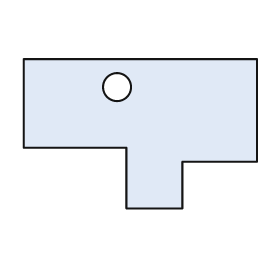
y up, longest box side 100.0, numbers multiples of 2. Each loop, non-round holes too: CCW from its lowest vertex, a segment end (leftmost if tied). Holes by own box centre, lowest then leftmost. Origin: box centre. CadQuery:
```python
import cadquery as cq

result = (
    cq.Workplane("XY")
    .moveTo(-6.0, -32.0)
    .lineTo(18.0, -32.0)
    .lineTo(18.0, -12.0)
    .lineTo(50.0, -12.0)
    .lineTo(50.0, 32.0)
    .lineTo(-50.0, 32.0)
    .lineTo(-50.0, -6.0)
    .lineTo(-6.0, -6.0)
    .close()
    .moveTo(-10.0, 20.0)
    .circle(6.0)
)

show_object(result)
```